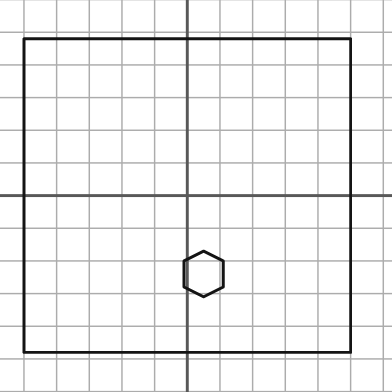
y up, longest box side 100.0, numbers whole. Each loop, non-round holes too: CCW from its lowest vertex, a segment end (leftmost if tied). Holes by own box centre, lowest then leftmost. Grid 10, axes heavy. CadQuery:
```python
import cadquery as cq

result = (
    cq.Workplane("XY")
    .moveTo(-50.0, -48.0)
    .lineTo(50.0, -48.0)
    .lineTo(50.0, 48.0)
    .lineTo(-50.0, 48.0)
    .close()
    .moveTo(5.0, -31.0)
    .lineTo(11.0, -28.0)
    .lineTo(11.0, -20.0)
    .lineTo(5.0, -17.0)
    .lineTo(-1.0, -20.0)
    .lineTo(-1.0, -28.0)
    .close()
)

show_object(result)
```